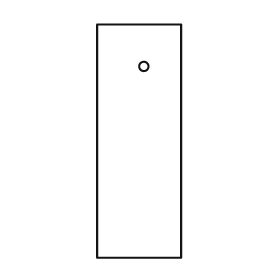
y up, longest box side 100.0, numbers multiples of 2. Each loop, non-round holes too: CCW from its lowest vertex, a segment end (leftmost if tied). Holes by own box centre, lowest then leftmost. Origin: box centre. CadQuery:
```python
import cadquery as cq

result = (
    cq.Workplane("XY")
    .moveTo(-18.0, -50.0)
    .lineTo(18.0, -50.0)
    .lineTo(18.0, 50.0)
    .lineTo(-18.0, 50.0)
    .close()
    .moveTo(2.0, 32.0)
    .circle(2.0)
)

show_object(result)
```